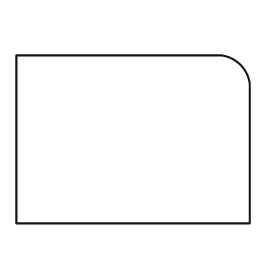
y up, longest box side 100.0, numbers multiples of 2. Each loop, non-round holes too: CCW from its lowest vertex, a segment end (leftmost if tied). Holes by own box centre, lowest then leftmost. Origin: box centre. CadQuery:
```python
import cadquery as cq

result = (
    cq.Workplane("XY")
    .moveTo(-50.0, -36.0)
    .lineTo(50.0, -36.0)
    .lineTo(50.0, 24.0)
    .threePointArc((46.0, 32.0), (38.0, 36.0))
    .lineTo(-50.0, 36.0)
    .close()
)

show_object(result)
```